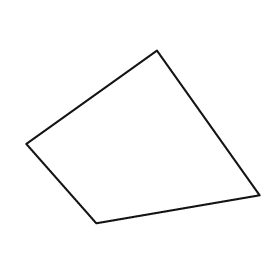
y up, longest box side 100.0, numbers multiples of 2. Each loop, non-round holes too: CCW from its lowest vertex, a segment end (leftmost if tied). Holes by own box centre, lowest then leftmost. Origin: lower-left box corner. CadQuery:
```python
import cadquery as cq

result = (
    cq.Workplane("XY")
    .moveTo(30.0, 0.0)
    .lineTo(100.0, 12.0)
    .lineTo(56.0, 74.0)
    .lineTo(0.0, 34.0)
    .close()
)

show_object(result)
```